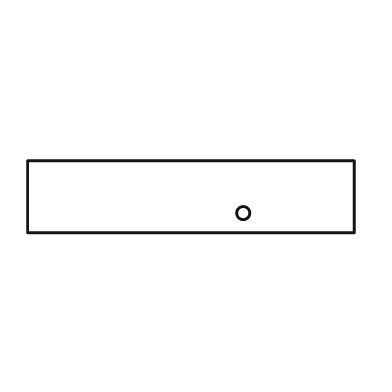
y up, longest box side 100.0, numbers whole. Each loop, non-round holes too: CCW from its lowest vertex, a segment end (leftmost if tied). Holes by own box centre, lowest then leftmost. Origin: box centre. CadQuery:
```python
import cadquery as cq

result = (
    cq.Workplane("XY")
    .moveTo(-50.0, -11.0)
    .lineTo(50.0, -11.0)
    .lineTo(50.0, 11.0)
    .lineTo(-50.0, 11.0)
    .close()
    .moveTo(16.0, -5.0)
    .circle(2.0)
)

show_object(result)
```